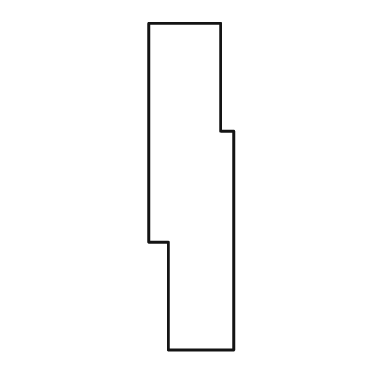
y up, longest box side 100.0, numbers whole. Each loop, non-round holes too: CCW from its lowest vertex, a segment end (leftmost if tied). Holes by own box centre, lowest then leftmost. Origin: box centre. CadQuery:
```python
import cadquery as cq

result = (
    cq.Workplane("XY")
    .moveTo(-7.0, -50.0)
    .lineTo(13.0, -50.0)
    .lineTo(13.0, 17.0)
    .lineTo(9.0, 17.0)
    .lineTo(9.0, 50.0)
    .lineTo(-13.0, 50.0)
    .lineTo(-13.0, -17.0)
    .lineTo(-7.0, -17.0)
    .close()
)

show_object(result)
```